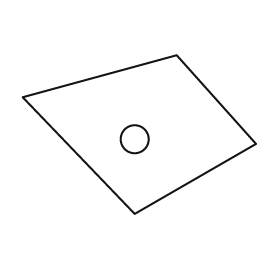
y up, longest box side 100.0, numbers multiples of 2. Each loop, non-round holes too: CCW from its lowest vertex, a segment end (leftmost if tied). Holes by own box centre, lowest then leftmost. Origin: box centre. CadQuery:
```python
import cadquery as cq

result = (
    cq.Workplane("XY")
    .moveTo(-2.0, -34.0)
    .lineTo(50.0, -4.0)
    .lineTo(16.0, 34.0)
    .lineTo(-50.0, 16.0)
    .close()
    .moveTo(-2.0, -2.0)
    .circle(6.0)
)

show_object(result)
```